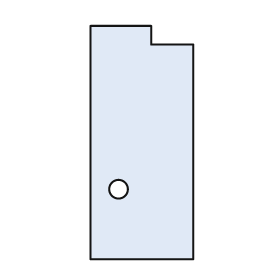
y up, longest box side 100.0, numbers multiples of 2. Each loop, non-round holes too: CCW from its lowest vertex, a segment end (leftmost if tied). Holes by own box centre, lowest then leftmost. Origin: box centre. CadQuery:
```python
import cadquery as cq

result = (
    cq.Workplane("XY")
    .moveTo(-22.0, -50.0)
    .lineTo(22.0, -50.0)
    .lineTo(22.0, 42.0)
    .lineTo(4.0, 42.0)
    .lineTo(4.0, 50.0)
    .lineTo(-22.0, 50.0)
    .close()
    .moveTo(-10.0, -20.0)
    .circle(4.0)
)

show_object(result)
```